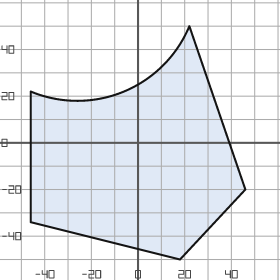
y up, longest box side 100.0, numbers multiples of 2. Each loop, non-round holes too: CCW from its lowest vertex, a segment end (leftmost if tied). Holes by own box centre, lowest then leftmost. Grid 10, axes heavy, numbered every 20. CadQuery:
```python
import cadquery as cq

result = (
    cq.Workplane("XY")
    .moveTo(18.0, -50.0)
    .lineTo(46.0, -20.0)
    .lineTo(22.0, 50.0)
    .threePointArc((-6.0, 22.0), (-46.0, 22.0))
    .lineTo(-46.0, -34.0)
    .close()
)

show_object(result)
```